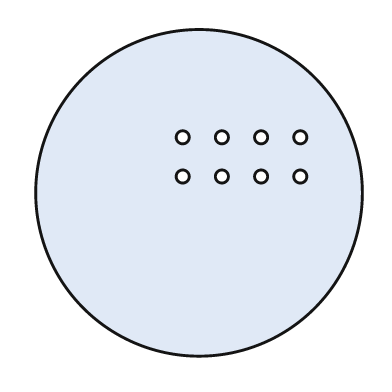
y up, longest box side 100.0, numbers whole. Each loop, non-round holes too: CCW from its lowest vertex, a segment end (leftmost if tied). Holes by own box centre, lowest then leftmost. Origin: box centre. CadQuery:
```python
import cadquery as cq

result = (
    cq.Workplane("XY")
    .moveTo(0.0, 0.0)
    .circle(50.0)
    .moveTo(-5.0, 5.0)
    .circle(2.0)
    .moveTo(7.0, 5.0)
    .circle(2.0)
    .moveTo(19.0, 5.0)
    .circle(2.0)
    .moveTo(31.0, 5.0)
    .circle(2.0)
    .moveTo(-5.0, 17.0)
    .circle(2.0)
    .moveTo(7.0, 17.0)
    .circle(2.0)
    .moveTo(19.0, 17.0)
    .circle(2.0)
    .moveTo(31.0, 17.0)
    .circle(2.0)
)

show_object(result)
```